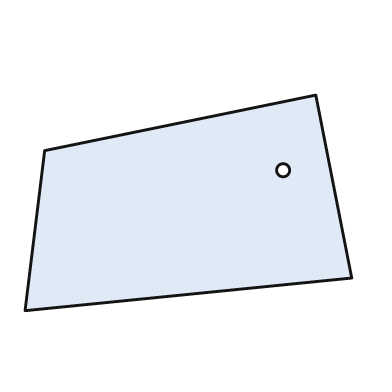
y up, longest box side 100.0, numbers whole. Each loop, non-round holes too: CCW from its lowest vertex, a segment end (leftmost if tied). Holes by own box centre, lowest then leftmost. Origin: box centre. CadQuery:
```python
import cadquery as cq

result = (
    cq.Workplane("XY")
    .moveTo(-50.0, -33.0)
    .lineTo(50.0, -23.0)
    .lineTo(39.0, 33.0)
    .lineTo(-44.0, 16.0)
    .close()
    .moveTo(29.0, 10.0)
    .circle(2.0)
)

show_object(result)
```